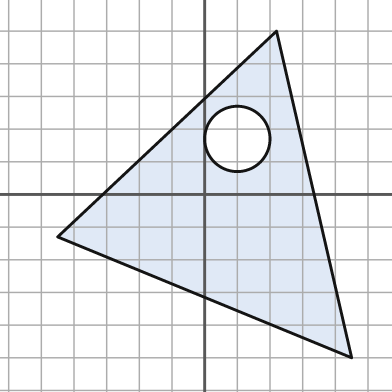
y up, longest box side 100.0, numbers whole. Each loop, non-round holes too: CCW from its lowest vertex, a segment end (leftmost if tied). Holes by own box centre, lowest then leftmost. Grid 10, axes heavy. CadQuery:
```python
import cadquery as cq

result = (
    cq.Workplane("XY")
    .moveTo(45.0, -50.0)
    .lineTo(22.0, 50.0)
    .lineTo(-45.0, -13.0)
    .close()
    .moveTo(10.0, 17.0)
    .circle(10.0)
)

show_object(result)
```